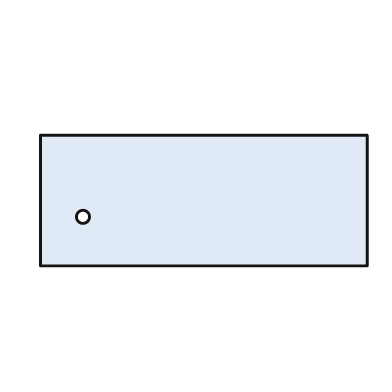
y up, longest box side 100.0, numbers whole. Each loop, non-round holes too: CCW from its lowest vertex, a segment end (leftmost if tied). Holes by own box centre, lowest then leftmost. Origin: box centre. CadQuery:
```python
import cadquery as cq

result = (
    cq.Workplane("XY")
    .moveTo(-50.0, -20.0)
    .lineTo(50.0, -20.0)
    .lineTo(50.0, 20.0)
    .lineTo(-50.0, 20.0)
    .close()
    .moveTo(-37.0, -5.0)
    .circle(2.0)
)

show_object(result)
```